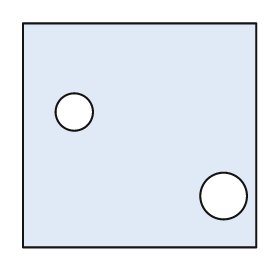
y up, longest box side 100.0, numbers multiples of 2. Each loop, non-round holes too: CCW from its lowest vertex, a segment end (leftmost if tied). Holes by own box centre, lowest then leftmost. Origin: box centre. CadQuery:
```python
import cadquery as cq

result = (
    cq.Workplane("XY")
    .moveTo(-50.0, -48.0)
    .lineTo(50.0, -48.0)
    .lineTo(50.0, 48.0)
    .lineTo(-50.0, 48.0)
    .close()
    .moveTo(36.0, -26.0)
    .circle(10.0)
    .moveTo(-28.0, 10.0)
    .circle(8.0)
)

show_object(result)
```